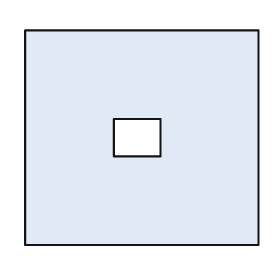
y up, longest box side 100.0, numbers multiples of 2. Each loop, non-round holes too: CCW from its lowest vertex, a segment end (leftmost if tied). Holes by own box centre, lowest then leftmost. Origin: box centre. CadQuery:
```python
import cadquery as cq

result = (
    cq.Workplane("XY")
    .moveTo(-50.0, -46.0)
    .lineTo(50.0, -46.0)
    .lineTo(50.0, 46.0)
    .lineTo(-50.0, 46.0)
    .close()
    .moveTo(-12.0, -8.0)
    .lineTo(8.0, -8.0)
    .lineTo(8.0, 8.0)
    .lineTo(-12.0, 8.0)
    .close()
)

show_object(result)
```